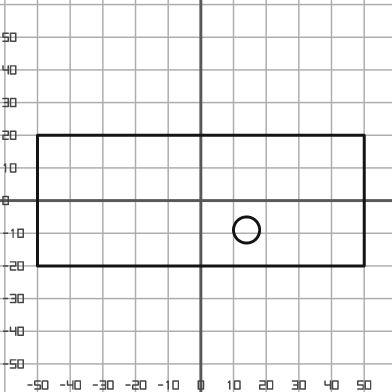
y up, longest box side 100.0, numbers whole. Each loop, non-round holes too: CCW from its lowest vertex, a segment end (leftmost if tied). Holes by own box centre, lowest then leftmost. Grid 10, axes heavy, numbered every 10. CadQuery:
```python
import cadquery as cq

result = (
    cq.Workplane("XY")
    .moveTo(-50.0, -20.0)
    .lineTo(50.0, -20.0)
    .lineTo(50.0, 20.0)
    .lineTo(-50.0, 20.0)
    .close()
    .moveTo(14.0, -9.0)
    .circle(4.0)
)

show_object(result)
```